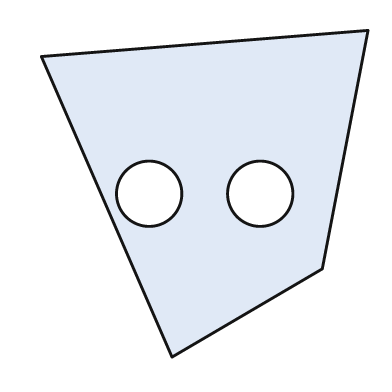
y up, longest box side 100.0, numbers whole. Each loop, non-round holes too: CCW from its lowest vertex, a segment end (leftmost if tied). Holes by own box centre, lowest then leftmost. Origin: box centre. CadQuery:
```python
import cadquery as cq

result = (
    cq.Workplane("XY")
    .moveTo(-10.0, -50.0)
    .lineTo(36.0, -23.0)
    .lineTo(50.0, 50.0)
    .lineTo(-50.0, 42.0)
    .close()
    .moveTo(-17.0, 0.0)
    .circle(10.0)
    .moveTo(17.0, 0.0)
    .circle(10.0)
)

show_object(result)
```